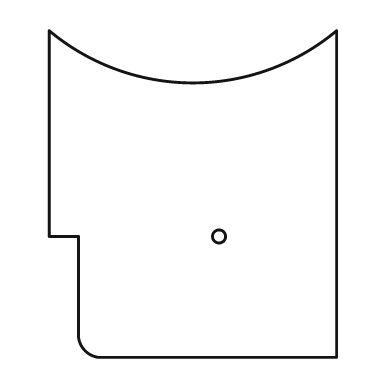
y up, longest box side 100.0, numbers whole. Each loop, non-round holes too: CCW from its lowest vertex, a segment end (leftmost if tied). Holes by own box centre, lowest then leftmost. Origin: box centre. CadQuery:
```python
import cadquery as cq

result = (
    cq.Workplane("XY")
    .moveTo(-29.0, -50.0)
    .lineTo(44.0, -50.0)
    .lineTo(44.0, 50.0)
    .threePointArc((0.0, 34.0), (-44.0, 50.0))
    .lineTo(-44.0, -13.0)
    .lineTo(-35.0, -13.0)
    .lineTo(-35.0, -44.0)
    .threePointArc((-33.0, -48.0), (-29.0, -50.0))
    .close()
    .moveTo(8.0, -13.0)
    .circle(2.0)
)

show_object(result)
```